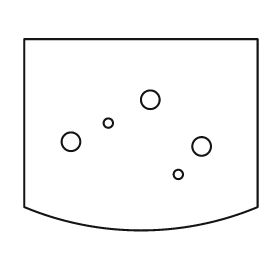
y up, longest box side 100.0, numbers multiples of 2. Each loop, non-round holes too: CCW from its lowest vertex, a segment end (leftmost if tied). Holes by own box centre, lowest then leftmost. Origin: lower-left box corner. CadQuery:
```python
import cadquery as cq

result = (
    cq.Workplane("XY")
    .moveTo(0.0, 10.0)
    .threePointArc((50.0, 0.0), (100.0, 10.0))
    .lineTo(100.0, 82.0)
    .lineTo(0.0, 82.0)
    .close()
    .moveTo(66.0, 24.0)
    .circle(2.0)
    .moveTo(76.0, 36.0)
    .circle(4.0)
    .moveTo(20.0, 38.0)
    .circle(4.0)
    .moveTo(36.0, 46.0)
    .circle(2.0)
    .moveTo(54.0, 56.0)
    .circle(4.0)
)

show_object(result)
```